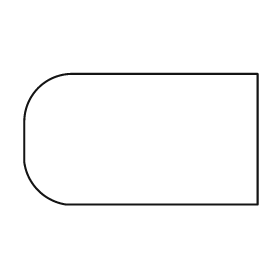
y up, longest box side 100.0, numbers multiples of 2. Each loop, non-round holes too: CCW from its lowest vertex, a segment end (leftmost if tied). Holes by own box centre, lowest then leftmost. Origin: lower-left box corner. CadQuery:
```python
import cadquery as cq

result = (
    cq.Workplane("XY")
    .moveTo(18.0, 0.0)
    .lineTo(100.0, 0.0)
    .lineTo(100.0, 56.0)
    .lineTo(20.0, 56.0)
    .threePointArc((6.0, 50.0), (0.0, 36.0))
    .lineTo(0.0, 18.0)
    .threePointArc((6.0, 6.0), (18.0, 0.0))
    .close()
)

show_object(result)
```